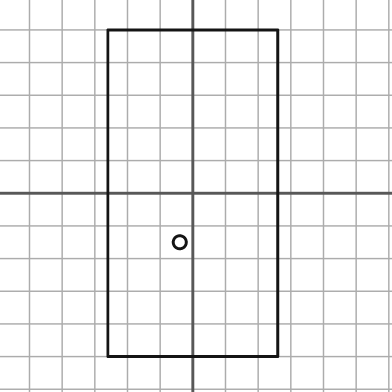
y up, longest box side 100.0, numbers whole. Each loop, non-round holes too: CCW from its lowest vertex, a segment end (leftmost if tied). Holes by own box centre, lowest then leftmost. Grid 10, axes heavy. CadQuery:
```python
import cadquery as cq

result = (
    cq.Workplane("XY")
    .moveTo(-26.0, -50.0)
    .lineTo(26.0, -50.0)
    .lineTo(26.0, 50.0)
    .lineTo(-26.0, 50.0)
    .close()
    .moveTo(-4.0, -15.0)
    .circle(2.0)
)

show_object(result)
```